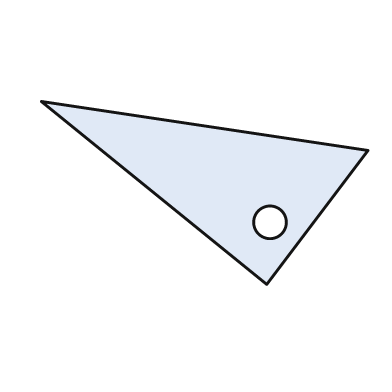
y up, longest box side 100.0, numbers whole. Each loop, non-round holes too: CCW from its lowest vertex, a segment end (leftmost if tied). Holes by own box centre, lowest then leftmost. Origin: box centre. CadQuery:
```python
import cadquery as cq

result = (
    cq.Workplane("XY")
    .moveTo(19.0, -28.0)
    .lineTo(50.0, 13.0)
    .lineTo(-50.0, 28.0)
    .close()
    .moveTo(20.0, -9.0)
    .circle(5.0)
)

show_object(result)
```